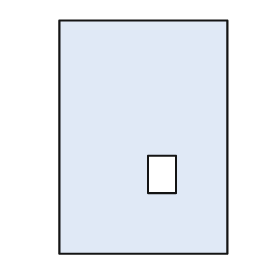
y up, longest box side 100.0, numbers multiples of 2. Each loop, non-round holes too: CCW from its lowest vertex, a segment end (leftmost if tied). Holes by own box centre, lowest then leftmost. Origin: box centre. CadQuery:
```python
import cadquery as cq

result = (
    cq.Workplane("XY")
    .moveTo(-36.0, -50.0)
    .lineTo(36.0, -50.0)
    .lineTo(36.0, 50.0)
    .lineTo(-36.0, 50.0)
    .close()
    .moveTo(2.0, -24.0)
    .lineTo(14.0, -24.0)
    .lineTo(14.0, -8.0)
    .lineTo(2.0, -8.0)
    .close()
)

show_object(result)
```